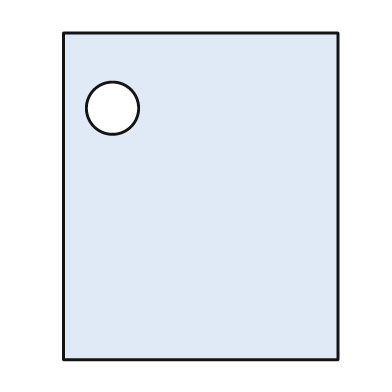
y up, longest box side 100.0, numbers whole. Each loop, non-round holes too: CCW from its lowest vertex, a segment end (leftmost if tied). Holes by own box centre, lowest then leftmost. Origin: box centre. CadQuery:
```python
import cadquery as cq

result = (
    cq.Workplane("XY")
    .moveTo(-42.0, -50.0)
    .lineTo(42.0, -50.0)
    .lineTo(42.0, 50.0)
    .lineTo(-42.0, 50.0)
    .close()
    .moveTo(-27.0, 27.0)
    .circle(8.0)
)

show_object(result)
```